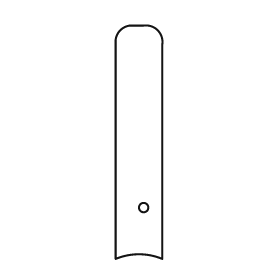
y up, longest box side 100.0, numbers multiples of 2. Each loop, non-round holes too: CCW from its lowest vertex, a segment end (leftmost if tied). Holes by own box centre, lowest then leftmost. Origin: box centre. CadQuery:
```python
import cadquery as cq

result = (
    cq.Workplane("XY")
    .moveTo(-10.0, -50.0)
    .threePointArc((0.0, -48.0), (10.0, -50.0))
    .lineTo(10.0, 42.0)
    .threePointArc((8.0, 48.0), (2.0, 50.0))
    .lineTo(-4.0, 50.0)
    .threePointArc((-8.0, 48.0), (-10.0, 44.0))
    .close()
    .moveTo(2.0, -28.0)
    .circle(2.0)
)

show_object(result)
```